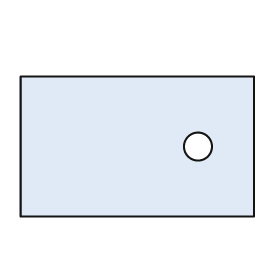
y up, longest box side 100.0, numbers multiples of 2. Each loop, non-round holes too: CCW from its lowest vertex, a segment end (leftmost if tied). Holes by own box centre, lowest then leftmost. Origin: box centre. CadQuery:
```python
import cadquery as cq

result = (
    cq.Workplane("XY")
    .moveTo(-50.0, -30.0)
    .lineTo(50.0, -30.0)
    .lineTo(50.0, 30.0)
    .lineTo(-50.0, 30.0)
    .close()
    .moveTo(26.0, 0.0)
    .circle(6.0)
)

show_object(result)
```